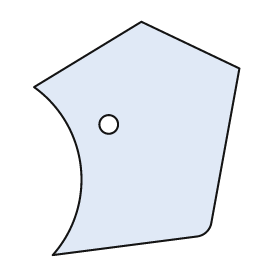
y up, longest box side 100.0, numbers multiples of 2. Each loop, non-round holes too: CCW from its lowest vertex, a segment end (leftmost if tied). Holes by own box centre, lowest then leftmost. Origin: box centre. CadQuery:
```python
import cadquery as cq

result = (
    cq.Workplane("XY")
    .moveTo(-36.0, -50.0)
    .lineTo(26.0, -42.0)
    .threePointArc((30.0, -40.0), (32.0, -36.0))
    .lineTo(44.0, 30.0)
    .lineTo(2.0, 50.0)
    .lineTo(-44.0, 22.0)
    .threePointArc((-24.0, -12.0), (-36.0, -50.0))
    .close()
    .moveTo(-12.0, 6.0)
    .circle(4.0)
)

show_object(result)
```